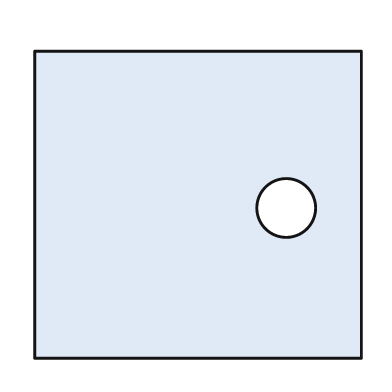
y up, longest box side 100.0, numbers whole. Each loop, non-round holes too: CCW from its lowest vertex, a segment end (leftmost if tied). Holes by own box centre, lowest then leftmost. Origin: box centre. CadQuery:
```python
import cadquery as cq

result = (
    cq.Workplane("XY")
    .moveTo(-50.0, -47.0)
    .lineTo(50.0, -47.0)
    .lineTo(50.0, 47.0)
    .lineTo(-50.0, 47.0)
    .close()
    .moveTo(27.0, -1.0)
    .circle(9.0)
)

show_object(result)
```